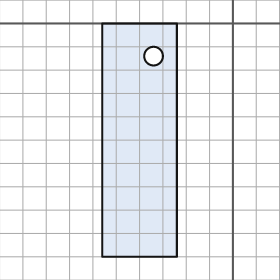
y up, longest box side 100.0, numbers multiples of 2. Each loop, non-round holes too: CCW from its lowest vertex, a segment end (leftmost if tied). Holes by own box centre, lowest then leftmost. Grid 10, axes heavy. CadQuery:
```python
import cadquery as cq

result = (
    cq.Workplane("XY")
    .moveTo(-56.0, -100.0)
    .lineTo(-24.0, -100.0)
    .lineTo(-24.0, 0.0)
    .lineTo(-56.0, 0.0)
    .close()
    .moveTo(-34.0, -14.0)
    .circle(4.0)
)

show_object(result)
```